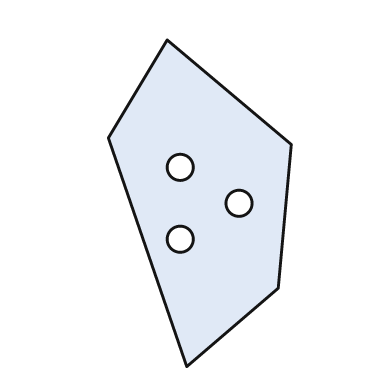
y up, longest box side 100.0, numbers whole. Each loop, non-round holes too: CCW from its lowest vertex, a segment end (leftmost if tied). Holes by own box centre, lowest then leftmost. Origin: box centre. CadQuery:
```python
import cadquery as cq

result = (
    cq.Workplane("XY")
    .moveTo(-4.0, -50.0)
    .lineTo(24.0, -26.0)
    .lineTo(28.0, 18.0)
    .lineTo(-10.0, 50.0)
    .lineTo(-28.0, 20.0)
    .close()
    .moveTo(-6.0, -11.0)
    .circle(4.0)
    .moveTo(12.0, 0.0)
    .circle(4.0)
    .moveTo(-6.0, 11.0)
    .circle(4.0)
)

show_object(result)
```